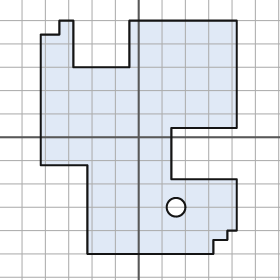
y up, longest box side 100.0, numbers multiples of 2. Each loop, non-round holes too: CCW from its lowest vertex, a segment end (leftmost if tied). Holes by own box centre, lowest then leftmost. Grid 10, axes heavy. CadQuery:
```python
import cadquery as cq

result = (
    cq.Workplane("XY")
    .moveTo(-22.0, -50.0)
    .lineTo(32.0, -50.0)
    .lineTo(32.0, -44.0)
    .lineTo(38.0, -44.0)
    .lineTo(38.0, -40.0)
    .lineTo(42.0, -40.0)
    .lineTo(42.0, -18.0)
    .lineTo(14.0, -18.0)
    .lineTo(14.0, 4.0)
    .lineTo(42.0, 4.0)
    .lineTo(42.0, 50.0)
    .lineTo(-4.0, 50.0)
    .lineTo(-4.0, 30.0)
    .lineTo(-28.0, 30.0)
    .lineTo(-28.0, 50.0)
    .lineTo(-34.0, 50.0)
    .lineTo(-34.0, 44.0)
    .lineTo(-42.0, 44.0)
    .lineTo(-42.0, -12.0)
    .lineTo(-22.0, -12.0)
    .close()
    .moveTo(16.0, -30.0)
    .circle(4.0)
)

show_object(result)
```